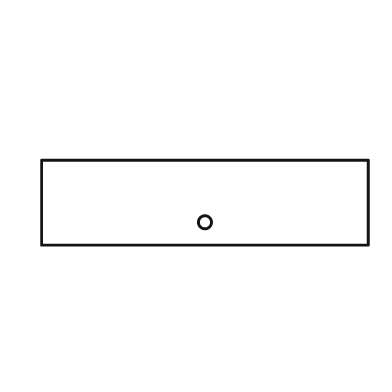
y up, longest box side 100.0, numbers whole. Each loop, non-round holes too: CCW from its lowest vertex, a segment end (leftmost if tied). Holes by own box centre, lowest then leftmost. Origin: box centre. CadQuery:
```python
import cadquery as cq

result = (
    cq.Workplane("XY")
    .moveTo(-50.0, -13.0)
    .lineTo(50.0, -13.0)
    .lineTo(50.0, 13.0)
    .lineTo(-50.0, 13.0)
    .close()
    .moveTo(0.0, -6.0)
    .circle(2.0)
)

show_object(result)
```